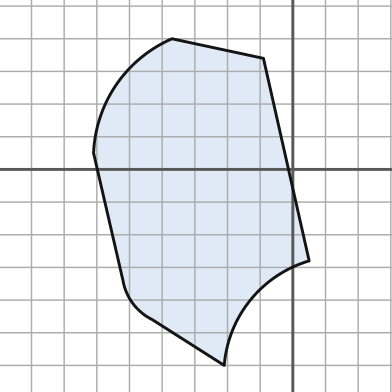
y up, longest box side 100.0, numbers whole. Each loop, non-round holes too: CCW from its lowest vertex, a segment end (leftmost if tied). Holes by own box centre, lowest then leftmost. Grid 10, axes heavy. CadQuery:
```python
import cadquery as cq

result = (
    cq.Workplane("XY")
    .moveTo(-21.0, -60.0)
    .threePointArc((-13.0, -40.0), (5.0, -28.0))
    .lineTo(-9.0, 34.0)
    .lineTo(-37.0, 40.0)
    .threePointArc((-54.0, 26.0), (-61.0, 5.0))
    .lineTo(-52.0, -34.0)
    .threePointArc((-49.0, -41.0), (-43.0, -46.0))
    .close()
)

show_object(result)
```